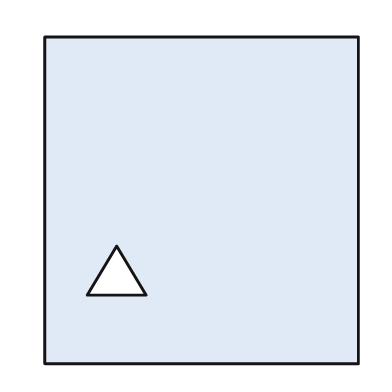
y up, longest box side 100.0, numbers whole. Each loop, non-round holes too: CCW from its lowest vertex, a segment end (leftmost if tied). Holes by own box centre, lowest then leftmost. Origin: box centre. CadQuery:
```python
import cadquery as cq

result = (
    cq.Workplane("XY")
    .moveTo(-48.0, -50.0)
    .lineTo(48.0, -50.0)
    .lineTo(48.0, 50.0)
    .lineTo(-48.0, 50.0)
    .close()
    .moveTo(-35.0, -29.0)
    .lineTo(-17.0, -29.0)
    .lineTo(-26.0, -14.0)
    .close()
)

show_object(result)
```